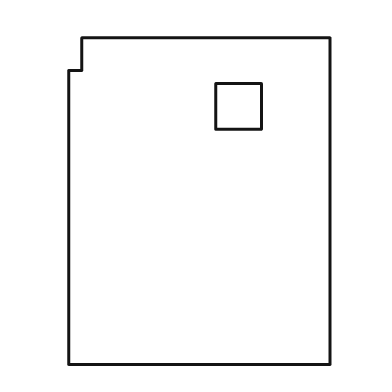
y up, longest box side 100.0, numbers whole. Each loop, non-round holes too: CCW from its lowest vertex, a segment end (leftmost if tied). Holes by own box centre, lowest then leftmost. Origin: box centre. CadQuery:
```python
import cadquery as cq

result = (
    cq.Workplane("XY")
    .moveTo(-40.0, -50.0)
    .lineTo(40.0, -50.0)
    .lineTo(40.0, 50.0)
    .lineTo(-36.0, 50.0)
    .lineTo(-36.0, 40.0)
    .lineTo(-40.0, 40.0)
    .close()
    .moveTo(5.0, 22.0)
    .lineTo(19.0, 22.0)
    .lineTo(19.0, 36.0)
    .lineTo(5.0, 36.0)
    .close()
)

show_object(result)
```